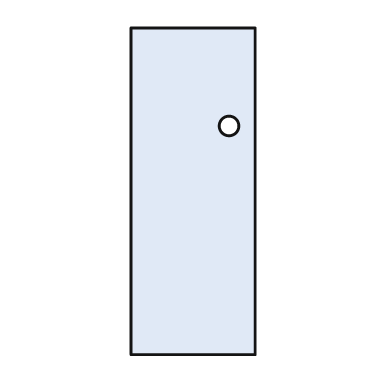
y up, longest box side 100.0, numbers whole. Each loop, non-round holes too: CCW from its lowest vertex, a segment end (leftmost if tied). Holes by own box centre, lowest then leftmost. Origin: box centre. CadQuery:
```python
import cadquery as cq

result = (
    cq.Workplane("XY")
    .moveTo(-19.0, -50.0)
    .lineTo(19.0, -50.0)
    .lineTo(19.0, 50.0)
    .lineTo(-19.0, 50.0)
    .close()
    .moveTo(11.0, 20.0)
    .circle(3.0)
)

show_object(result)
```